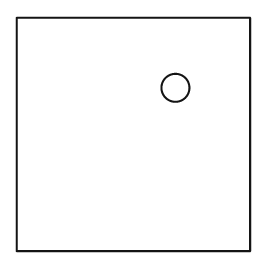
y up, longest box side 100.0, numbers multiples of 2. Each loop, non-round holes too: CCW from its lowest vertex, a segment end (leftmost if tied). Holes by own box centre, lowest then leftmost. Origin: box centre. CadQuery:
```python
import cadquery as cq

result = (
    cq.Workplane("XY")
    .moveTo(-50.0, -50.0)
    .lineTo(50.0, -50.0)
    .lineTo(50.0, 50.0)
    .lineTo(-50.0, 50.0)
    .close()
    .moveTo(18.0, 20.0)
    .circle(6.0)
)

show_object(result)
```